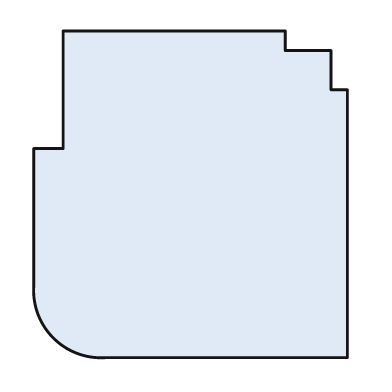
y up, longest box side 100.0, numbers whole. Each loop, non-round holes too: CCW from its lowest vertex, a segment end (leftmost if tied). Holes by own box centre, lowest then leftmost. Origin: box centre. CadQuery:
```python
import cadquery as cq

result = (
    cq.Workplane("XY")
    .moveTo(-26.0, -50.0)
    .lineTo(48.0, -50.0)
    .lineTo(48.0, 32.0)
    .lineTo(43.0, 32.0)
    .lineTo(43.0, 44.0)
    .lineTo(29.0, 44.0)
    .lineTo(29.0, 50.0)
    .lineTo(-39.0, 50.0)
    .lineTo(-39.0, 14.0)
    .lineTo(-48.0, 14.0)
    .lineTo(-48.0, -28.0)
    .threePointArc((-42.0, -44.0), (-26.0, -50.0))
    .close()
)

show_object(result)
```